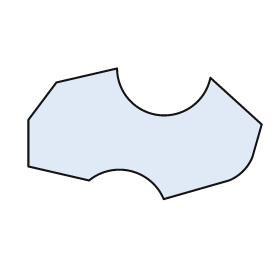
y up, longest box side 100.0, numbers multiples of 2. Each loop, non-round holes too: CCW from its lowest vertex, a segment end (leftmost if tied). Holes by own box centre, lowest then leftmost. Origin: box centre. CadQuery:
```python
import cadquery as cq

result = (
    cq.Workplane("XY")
    .moveTo(8.0, -28.0)
    .lineTo(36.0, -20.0)
    .threePointArc((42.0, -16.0), (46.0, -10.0))
    .lineTo(50.0, 4.0)
    .lineTo(28.0, 24.0)
    .threePointArc((6.0, 8.0), (-12.0, 28.0))
    .lineTo(-38.0, 22.0)
    .lineTo(-50.0, 6.0)
    .lineTo(-50.0, -14.0)
    .lineTo(-24.0, -20.0)
    .threePointArc((-6.0, -16.0), (8.0, -28.0))
    .close()
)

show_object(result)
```